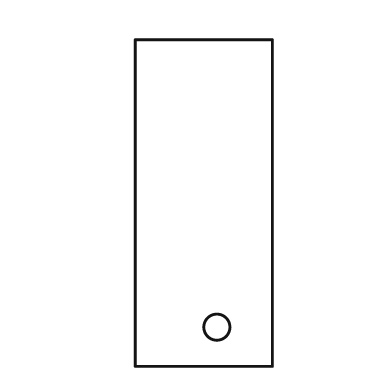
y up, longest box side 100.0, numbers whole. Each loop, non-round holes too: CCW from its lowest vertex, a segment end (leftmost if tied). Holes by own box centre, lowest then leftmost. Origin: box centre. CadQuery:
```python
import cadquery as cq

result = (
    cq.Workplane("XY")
    .moveTo(-21.0, -50.0)
    .lineTo(21.0, -50.0)
    .lineTo(21.0, 50.0)
    .lineTo(-21.0, 50.0)
    .close()
    .moveTo(4.0, -38.0)
    .circle(4.0)
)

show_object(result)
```